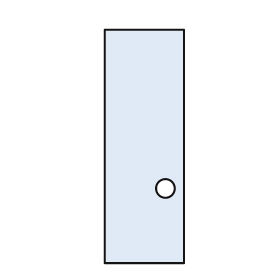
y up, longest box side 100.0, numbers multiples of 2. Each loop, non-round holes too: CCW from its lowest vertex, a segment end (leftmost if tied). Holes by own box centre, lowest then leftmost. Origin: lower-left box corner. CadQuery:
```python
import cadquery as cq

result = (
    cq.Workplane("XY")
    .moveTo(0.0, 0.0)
    .lineTo(34.0, 0.0)
    .lineTo(34.0, 100.0)
    .lineTo(0.0, 100.0)
    .close()
    .moveTo(26.0, 32.0)
    .circle(4.0)
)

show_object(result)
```